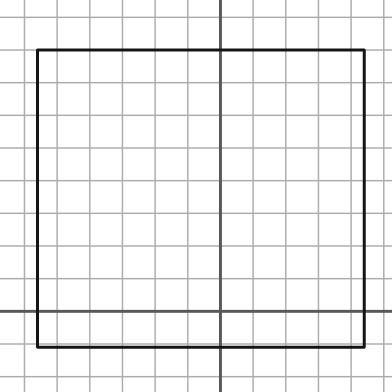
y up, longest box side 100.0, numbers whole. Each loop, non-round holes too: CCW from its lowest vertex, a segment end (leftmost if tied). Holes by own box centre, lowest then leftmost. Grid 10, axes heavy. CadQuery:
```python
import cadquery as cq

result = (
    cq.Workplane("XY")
    .moveTo(-56.0, -11.0)
    .lineTo(44.0, -11.0)
    .lineTo(44.0, 80.0)
    .lineTo(-56.0, 80.0)
    .close()
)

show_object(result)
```